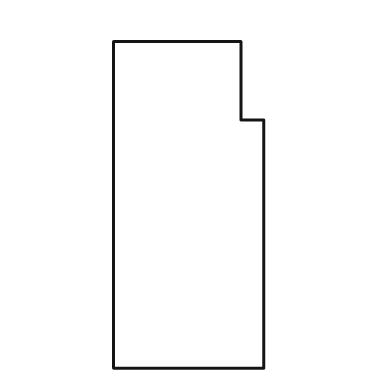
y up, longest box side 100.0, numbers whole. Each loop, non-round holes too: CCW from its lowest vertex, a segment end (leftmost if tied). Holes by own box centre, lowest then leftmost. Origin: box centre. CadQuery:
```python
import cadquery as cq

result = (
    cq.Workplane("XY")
    .moveTo(-23.0, -50.0)
    .lineTo(23.0, -50.0)
    .lineTo(23.0, 26.0)
    .lineTo(16.0, 26.0)
    .lineTo(16.0, 50.0)
    .lineTo(-23.0, 50.0)
    .close()
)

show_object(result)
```